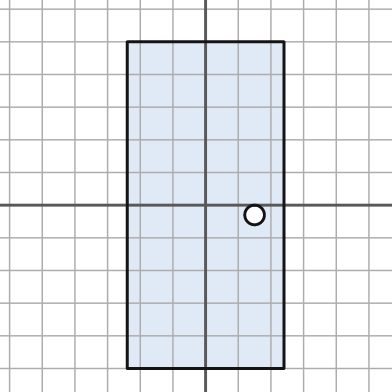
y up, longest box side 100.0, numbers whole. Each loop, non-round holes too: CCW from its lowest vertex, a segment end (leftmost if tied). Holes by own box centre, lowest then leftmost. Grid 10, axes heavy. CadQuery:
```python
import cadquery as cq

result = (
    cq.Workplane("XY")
    .moveTo(-24.0, -50.0)
    .lineTo(24.0, -50.0)
    .lineTo(24.0, 50.0)
    .lineTo(-24.0, 50.0)
    .close()
    .moveTo(15.0, -3.0)
    .circle(3.0)
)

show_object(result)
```